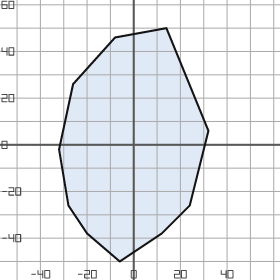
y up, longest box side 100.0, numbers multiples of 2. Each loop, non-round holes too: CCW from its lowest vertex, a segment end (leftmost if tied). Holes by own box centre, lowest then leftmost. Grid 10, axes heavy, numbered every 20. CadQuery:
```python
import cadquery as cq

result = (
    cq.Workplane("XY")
    .moveTo(-6.0, -50.0)
    .lineTo(12.0, -38.0)
    .lineTo(24.0, -26.0)
    .lineTo(32.0, 6.0)
    .lineTo(14.0, 50.0)
    .lineTo(-8.0, 46.0)
    .lineTo(-26.0, 26.0)
    .lineTo(-32.0, -2.0)
    .lineTo(-28.0, -26.0)
    .lineTo(-20.0, -38.0)
    .close()
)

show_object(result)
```